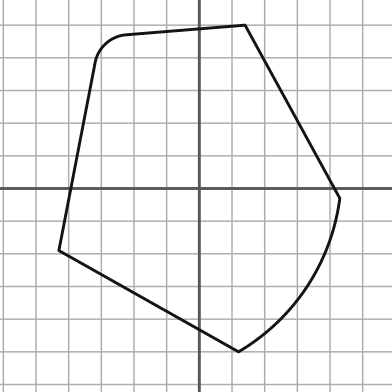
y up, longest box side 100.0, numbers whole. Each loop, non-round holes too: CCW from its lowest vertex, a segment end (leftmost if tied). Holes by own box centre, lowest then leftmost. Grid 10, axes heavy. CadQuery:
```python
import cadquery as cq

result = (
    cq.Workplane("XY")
    .moveTo(12.0, -50.0)
    .threePointArc((33.0, -30.0), (43.0, -3.0))
    .lineTo(14.0, 50.0)
    .lineTo(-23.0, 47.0)
    .threePointArc((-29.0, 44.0), (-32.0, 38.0))
    .lineTo(-43.0, -19.0)
    .close()
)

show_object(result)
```